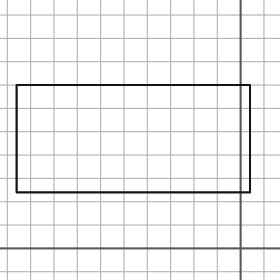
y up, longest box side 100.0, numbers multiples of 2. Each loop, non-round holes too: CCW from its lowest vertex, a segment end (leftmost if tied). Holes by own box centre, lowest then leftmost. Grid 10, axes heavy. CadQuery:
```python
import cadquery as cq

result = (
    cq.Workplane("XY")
    .moveTo(-96.0, 24.0)
    .lineTo(4.0, 24.0)
    .lineTo(4.0, 70.0)
    .lineTo(-96.0, 70.0)
    .close()
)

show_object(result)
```